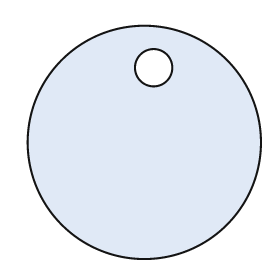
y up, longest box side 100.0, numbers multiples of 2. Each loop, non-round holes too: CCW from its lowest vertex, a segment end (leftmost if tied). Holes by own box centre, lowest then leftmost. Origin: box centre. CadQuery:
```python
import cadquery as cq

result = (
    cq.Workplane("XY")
    .moveTo(0.0, 0.0)
    .circle(50.0)
    .moveTo(4.0, 32.0)
    .circle(8.0)
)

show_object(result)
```